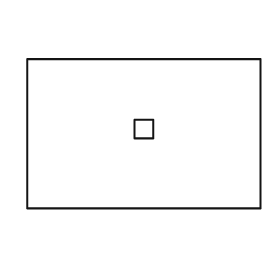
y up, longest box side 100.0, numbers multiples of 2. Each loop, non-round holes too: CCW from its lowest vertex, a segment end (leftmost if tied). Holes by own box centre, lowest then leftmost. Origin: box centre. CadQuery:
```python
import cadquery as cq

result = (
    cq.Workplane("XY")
    .moveTo(-50.0, -32.0)
    .lineTo(50.0, -32.0)
    .lineTo(50.0, 32.0)
    .lineTo(-50.0, 32.0)
    .close()
    .moveTo(-4.0, -2.0)
    .lineTo(4.0, -2.0)
    .lineTo(4.0, 6.0)
    .lineTo(-4.0, 6.0)
    .close()
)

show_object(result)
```